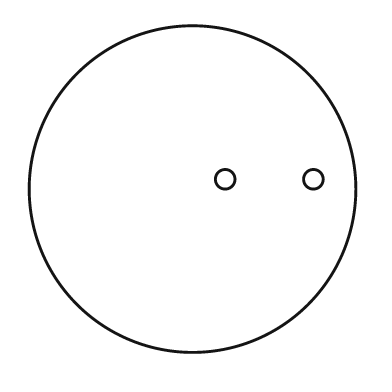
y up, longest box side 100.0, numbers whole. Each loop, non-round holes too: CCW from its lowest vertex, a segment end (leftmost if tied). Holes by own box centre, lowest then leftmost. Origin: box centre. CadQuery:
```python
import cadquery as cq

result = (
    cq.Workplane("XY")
    .moveTo(0.0, 0.0)
    .circle(50.0)
    .moveTo(10.0, 3.0)
    .circle(3.0)
    .moveTo(37.0, 3.0)
    .circle(3.0)
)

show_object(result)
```